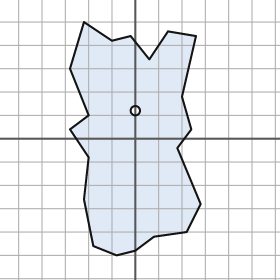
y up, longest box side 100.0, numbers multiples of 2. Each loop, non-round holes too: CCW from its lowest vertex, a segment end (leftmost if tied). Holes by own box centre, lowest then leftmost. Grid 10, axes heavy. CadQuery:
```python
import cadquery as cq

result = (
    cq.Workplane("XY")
    .moveTo(-8.0, -50.0)
    .lineTo(0.0, -48.0)
    .lineTo(8.0, -42.0)
    .lineTo(22.0, -40.0)
    .lineTo(28.0, -28.0)
    .lineTo(18.0, -4.0)
    .lineTo(24.0, 4.0)
    .lineTo(20.0, 18.0)
    .lineTo(26.0, 44.0)
    .lineTo(14.0, 46.0)
    .lineTo(6.0, 34.0)
    .lineTo(-2.0, 44.0)
    .lineTo(-10.0, 42.0)
    .lineTo(-22.0, 50.0)
    .lineTo(-28.0, 30.0)
    .lineTo(-20.0, 10.0)
    .lineTo(-28.0, 4.0)
    .lineTo(-20.0, -8.0)
    .lineTo(-22.0, -26.0)
    .lineTo(-18.0, -46.0)
    .close()
    .moveTo(0.0, 12.0)
    .circle(2.0)
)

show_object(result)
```